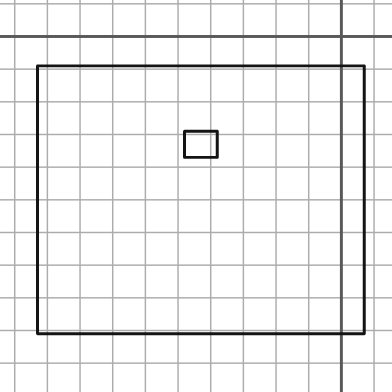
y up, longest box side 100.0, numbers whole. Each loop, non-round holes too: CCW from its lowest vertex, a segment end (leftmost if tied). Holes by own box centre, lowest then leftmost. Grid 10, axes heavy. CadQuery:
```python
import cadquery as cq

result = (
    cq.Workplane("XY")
    .moveTo(-93.0, -91.0)
    .lineTo(7.0, -91.0)
    .lineTo(7.0, -9.0)
    .lineTo(-93.0, -9.0)
    .close()
    .moveTo(-48.0, -37.0)
    .lineTo(-38.0, -37.0)
    .lineTo(-38.0, -29.0)
    .lineTo(-48.0, -29.0)
    .close()
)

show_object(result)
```